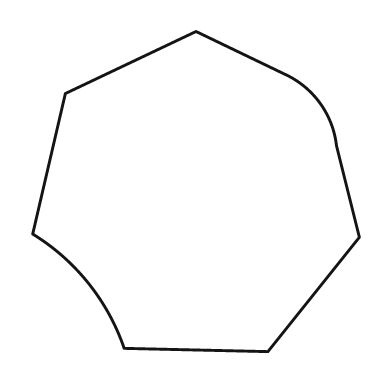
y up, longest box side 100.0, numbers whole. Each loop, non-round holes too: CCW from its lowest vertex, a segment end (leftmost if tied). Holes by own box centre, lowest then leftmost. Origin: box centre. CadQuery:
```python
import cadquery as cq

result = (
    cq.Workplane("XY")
    .moveTo(22.0, -49.0)
    .lineTo(50.0, -14.0)
    .lineTo(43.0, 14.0)
    .threePointArc((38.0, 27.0), (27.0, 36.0))
    .lineTo(0.0, 49.0)
    .lineTo(-40.0, 30.0)
    .lineTo(-50.0, -13.0)
    .threePointArc((-33.0, -28.0), (-22.0, -48.0))
    .close()
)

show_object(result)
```